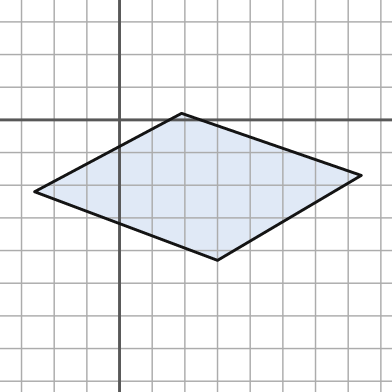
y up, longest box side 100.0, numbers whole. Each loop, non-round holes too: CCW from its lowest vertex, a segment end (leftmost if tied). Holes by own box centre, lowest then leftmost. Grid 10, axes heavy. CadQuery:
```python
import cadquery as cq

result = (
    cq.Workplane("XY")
    .moveTo(30.0, -43.0)
    .lineTo(74.0, -17.0)
    .lineTo(19.0, 2.0)
    .lineTo(-26.0, -22.0)
    .close()
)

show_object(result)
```